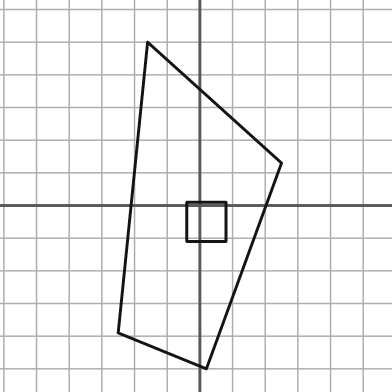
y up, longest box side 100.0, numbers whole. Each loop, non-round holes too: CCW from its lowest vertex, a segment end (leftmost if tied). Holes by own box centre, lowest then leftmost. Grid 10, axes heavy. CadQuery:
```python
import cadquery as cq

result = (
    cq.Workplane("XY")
    .moveTo(2.0, -50.0)
    .lineTo(25.0, 13.0)
    .lineTo(-16.0, 50.0)
    .lineTo(-25.0, -39.0)
    .close()
    .moveTo(-4.0, -11.0)
    .lineTo(8.0, -11.0)
    .lineTo(8.0, 1.0)
    .lineTo(-4.0, 1.0)
    .close()
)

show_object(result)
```